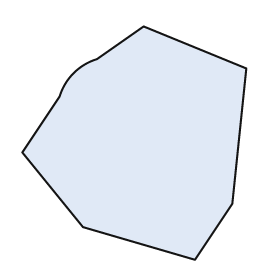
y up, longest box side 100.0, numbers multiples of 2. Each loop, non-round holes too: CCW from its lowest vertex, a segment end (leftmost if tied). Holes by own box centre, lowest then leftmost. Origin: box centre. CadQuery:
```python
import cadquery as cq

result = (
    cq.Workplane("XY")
    .moveTo(26.0, -50.0)
    .lineTo(42.0, -26.0)
    .lineTo(48.0, 32.0)
    .lineTo(4.0, 50.0)
    .lineTo(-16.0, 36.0)
    .threePointArc((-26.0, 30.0), (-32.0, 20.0))
    .lineTo(-48.0, -4.0)
    .lineTo(-22.0, -36.0)
    .close()
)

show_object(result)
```